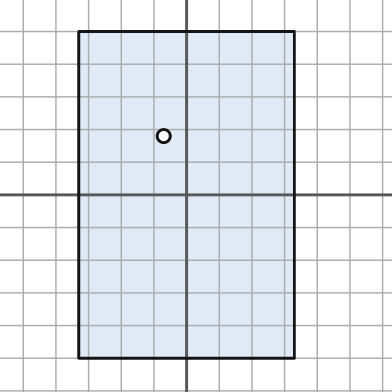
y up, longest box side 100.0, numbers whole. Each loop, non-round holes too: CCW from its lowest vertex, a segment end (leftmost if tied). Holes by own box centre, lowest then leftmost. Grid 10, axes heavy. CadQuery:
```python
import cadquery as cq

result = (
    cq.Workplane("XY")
    .moveTo(-33.0, -50.0)
    .lineTo(33.0, -50.0)
    .lineTo(33.0, 50.0)
    .lineTo(-33.0, 50.0)
    .close()
    .moveTo(-7.0, 18.0)
    .circle(2.0)
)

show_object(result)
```